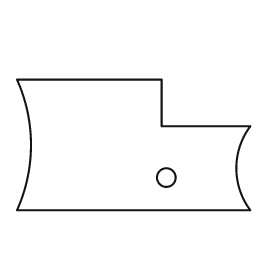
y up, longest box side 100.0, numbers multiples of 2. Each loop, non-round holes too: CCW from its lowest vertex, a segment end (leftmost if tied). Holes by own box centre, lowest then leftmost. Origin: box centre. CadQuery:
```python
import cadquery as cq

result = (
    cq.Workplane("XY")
    .moveTo(-50.0, -28.0)
    .lineTo(50.0, -28.0)
    .threePointArc((44.0, -10.0), (50.0, 8.0))
    .lineTo(12.0, 8.0)
    .lineTo(12.0, 28.0)
    .lineTo(-50.0, 28.0)
    .threePointArc((-44.0, 0.0), (-50.0, -28.0))
    .close()
    .moveTo(14.0, -14.0)
    .circle(4.0)
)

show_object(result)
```